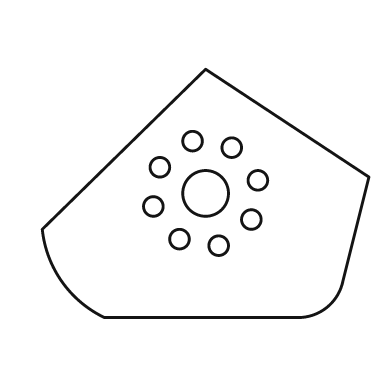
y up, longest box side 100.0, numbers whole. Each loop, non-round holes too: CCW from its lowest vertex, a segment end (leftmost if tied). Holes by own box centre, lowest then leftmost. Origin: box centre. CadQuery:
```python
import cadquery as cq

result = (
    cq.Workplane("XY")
    .moveTo(-31.0, -38.0)
    .lineTo(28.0, -38.0)
    .threePointArc((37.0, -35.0), (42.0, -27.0))
    .lineTo(50.0, 5.0)
    .lineTo(0.0, 38.0)
    .lineTo(-50.0, -11.0)
    .threePointArc((-44.0, -27.0), (-31.0, -38.0))
    .close()
    .moveTo(4.0, -16.0)
    .circle(3.0)
    .moveTo(-8.0, -14.0)
    .circle(3.0)
    .moveTo(14.0, -8.0)
    .circle(3.0)
    .moveTo(-16.0, -4.0)
    .circle(3.0)
    .moveTo(0.0, 0.0)
    .circle(7.0)
    .moveTo(16.0, 4.0)
    .circle(3.0)
    .moveTo(-14.0, 8.0)
    .circle(3.0)
    .moveTo(8.0, 14.0)
    .circle(3.0)
    .moveTo(-4.0, 16.0)
    .circle(3.0)
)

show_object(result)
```